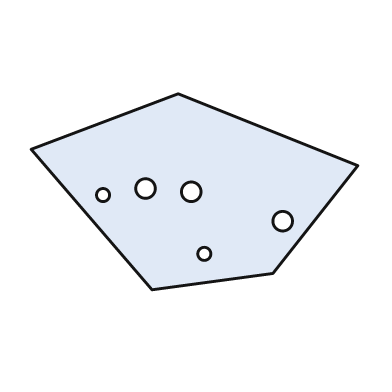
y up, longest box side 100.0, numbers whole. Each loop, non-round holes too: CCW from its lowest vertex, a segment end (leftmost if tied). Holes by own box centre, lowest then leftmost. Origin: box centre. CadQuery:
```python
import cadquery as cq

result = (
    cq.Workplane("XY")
    .moveTo(-13.0, -30.0)
    .lineTo(24.0, -25.0)
    .lineTo(50.0, 8.0)
    .lineTo(-5.0, 30.0)
    .lineTo(-50.0, 13.0)
    .close()
    .moveTo(3.0, -19.0)
    .circle(2.0)
    .moveTo(27.0, -9.0)
    .circle(3.0)
    .moveTo(-28.0, -1.0)
    .circle(2.0)
    .moveTo(-1.0, 0.0)
    .circle(3.0)
    .moveTo(-15.0, 1.0)
    .circle(3.0)
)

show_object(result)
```